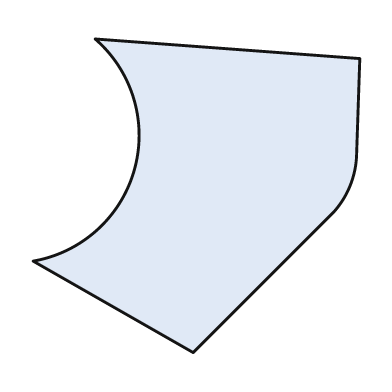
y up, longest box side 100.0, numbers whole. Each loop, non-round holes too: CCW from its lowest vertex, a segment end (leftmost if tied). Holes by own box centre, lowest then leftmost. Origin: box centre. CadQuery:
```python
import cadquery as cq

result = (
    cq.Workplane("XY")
    .moveTo(-1.0, -48.0)
    .lineTo(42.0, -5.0)
    .threePointArc((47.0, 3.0), (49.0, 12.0))
    .lineTo(50.0, 42.0)
    .lineTo(-31.0, 48.0)
    .threePointArc((-19.0, 8.0), (-50.0, -20.0))
    .close()
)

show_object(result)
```